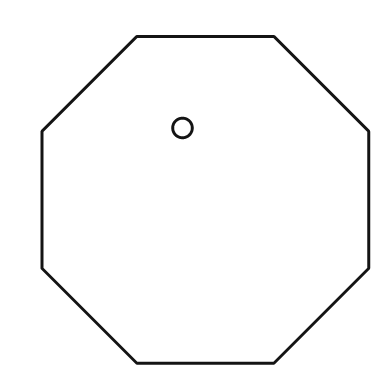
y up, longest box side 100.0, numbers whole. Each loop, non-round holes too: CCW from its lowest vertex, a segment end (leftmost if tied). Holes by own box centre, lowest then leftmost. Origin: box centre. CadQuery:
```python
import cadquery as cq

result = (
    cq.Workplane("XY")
    .moveTo(-21.0, -50.0)
    .lineTo(21.0, -50.0)
    .lineTo(50.0, -21.0)
    .lineTo(50.0, 21.0)
    .lineTo(21.0, 50.0)
    .lineTo(-21.0, 50.0)
    .lineTo(-50.0, 21.0)
    .lineTo(-50.0, -21.0)
    .close()
    .moveTo(-7.0, 22.0)
    .circle(3.0)
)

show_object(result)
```